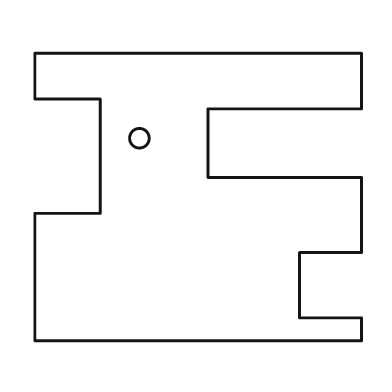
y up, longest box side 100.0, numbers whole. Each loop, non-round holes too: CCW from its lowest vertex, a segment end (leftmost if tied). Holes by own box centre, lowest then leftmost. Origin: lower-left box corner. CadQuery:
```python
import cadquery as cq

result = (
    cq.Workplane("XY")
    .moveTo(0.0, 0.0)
    .lineTo(100.0, 0.0)
    .lineTo(100.0, 7.0)
    .lineTo(81.0, 7.0)
    .lineTo(81.0, 27.0)
    .lineTo(100.0, 27.0)
    .lineTo(100.0, 50.0)
    .lineTo(53.0, 50.0)
    .lineTo(53.0, 71.0)
    .lineTo(100.0, 71.0)
    .lineTo(100.0, 88.0)
    .lineTo(0.0, 88.0)
    .lineTo(0.0, 74.0)
    .lineTo(20.0, 74.0)
    .lineTo(20.0, 39.0)
    .lineTo(0.0, 39.0)
    .close()
    .moveTo(32.0, 62.0)
    .circle(3.0)
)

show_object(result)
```